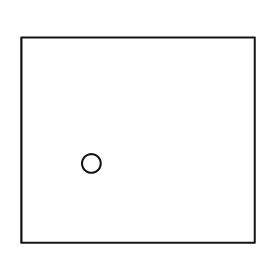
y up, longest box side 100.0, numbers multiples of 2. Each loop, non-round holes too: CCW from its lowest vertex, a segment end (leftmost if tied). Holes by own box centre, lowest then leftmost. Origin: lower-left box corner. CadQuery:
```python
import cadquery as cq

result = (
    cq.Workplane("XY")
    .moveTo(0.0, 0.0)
    .lineTo(100.0, 0.0)
    .lineTo(100.0, 88.0)
    .lineTo(0.0, 88.0)
    .close()
    .moveTo(30.0, 34.0)
    .circle(4.0)
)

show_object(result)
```